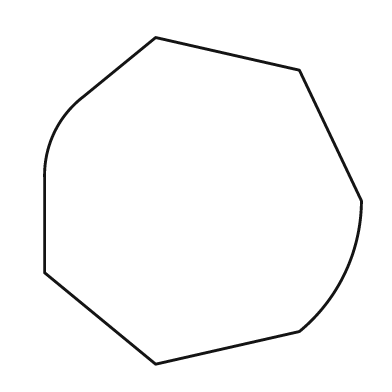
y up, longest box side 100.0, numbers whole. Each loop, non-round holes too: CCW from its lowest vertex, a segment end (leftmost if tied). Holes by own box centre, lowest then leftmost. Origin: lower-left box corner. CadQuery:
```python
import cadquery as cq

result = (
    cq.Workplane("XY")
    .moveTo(34.0, 0.0)
    .lineTo(78.0, 10.0)
    .threePointArc((92.0, 28.0), (97.0, 50.0))
    .lineTo(78.0, 90.0)
    .lineTo(34.0, 100.0)
    .lineTo(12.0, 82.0)
    .threePointArc((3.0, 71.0), (0.0, 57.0))
    .lineTo(0.0, 28.0)
    .close()
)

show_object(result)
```